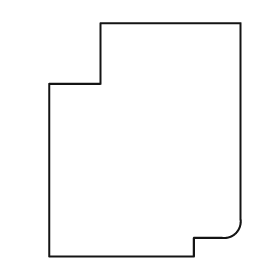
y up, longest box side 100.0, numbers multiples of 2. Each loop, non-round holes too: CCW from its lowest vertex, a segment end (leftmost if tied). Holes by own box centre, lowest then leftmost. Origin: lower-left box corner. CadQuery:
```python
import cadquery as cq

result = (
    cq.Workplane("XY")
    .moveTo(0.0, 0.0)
    .lineTo(62.0, 0.0)
    .lineTo(62.0, 8.0)
    .lineTo(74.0, 8.0)
    .threePointArc((80.0, 10.0), (82.0, 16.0))
    .lineTo(82.0, 100.0)
    .lineTo(22.0, 100.0)
    .lineTo(22.0, 74.0)
    .lineTo(0.0, 74.0)
    .close()
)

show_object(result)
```